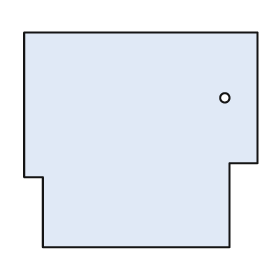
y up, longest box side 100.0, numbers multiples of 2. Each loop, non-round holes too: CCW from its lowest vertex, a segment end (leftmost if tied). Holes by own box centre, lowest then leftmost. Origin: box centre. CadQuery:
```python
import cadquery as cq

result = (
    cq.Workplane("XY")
    .moveTo(-42.0, -46.0)
    .lineTo(38.0, -46.0)
    .lineTo(38.0, -10.0)
    .lineTo(50.0, -10.0)
    .lineTo(50.0, 46.0)
    .lineTo(-50.0, 46.0)
    .lineTo(-50.0, -16.0)
    .lineTo(-42.0, -16.0)
    .close()
    .moveTo(36.0, 18.0)
    .circle(2.0)
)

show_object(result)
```